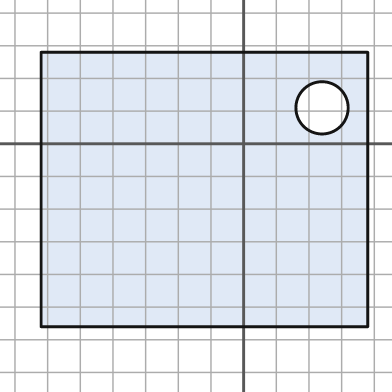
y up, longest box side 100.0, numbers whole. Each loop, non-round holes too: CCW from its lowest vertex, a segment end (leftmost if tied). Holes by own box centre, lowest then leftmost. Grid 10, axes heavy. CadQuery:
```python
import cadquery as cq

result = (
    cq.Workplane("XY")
    .moveTo(-62.0, -56.0)
    .lineTo(38.0, -56.0)
    .lineTo(38.0, 28.0)
    .lineTo(-62.0, 28.0)
    .close()
    .moveTo(24.0, 11.0)
    .circle(8.0)
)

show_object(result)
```